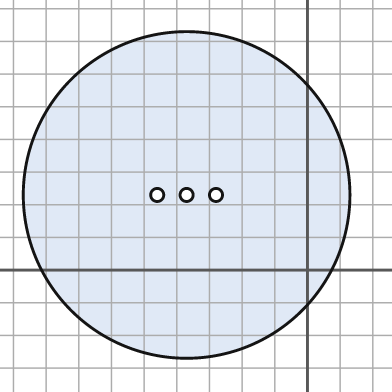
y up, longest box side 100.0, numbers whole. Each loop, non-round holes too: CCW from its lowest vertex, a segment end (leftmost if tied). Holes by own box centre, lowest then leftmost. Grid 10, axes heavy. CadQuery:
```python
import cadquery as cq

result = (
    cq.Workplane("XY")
    .moveTo(-37.0, 23.0)
    .circle(50.0)
    .moveTo(-46.0, 23.0)
    .circle(2.0)
    .moveTo(-37.0, 23.0)
    .circle(2.0)
    .moveTo(-28.0, 23.0)
    .circle(2.0)
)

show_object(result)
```